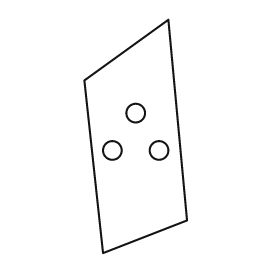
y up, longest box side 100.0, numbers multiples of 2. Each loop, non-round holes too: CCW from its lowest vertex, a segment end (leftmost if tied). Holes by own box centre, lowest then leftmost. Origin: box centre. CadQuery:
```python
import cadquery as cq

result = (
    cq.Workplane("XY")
    .moveTo(-14.0, -50.0)
    .lineTo(22.0, -36.0)
    .lineTo(14.0, 50.0)
    .lineTo(-22.0, 24.0)
    .close()
    .moveTo(-10.0, -6.0)
    .circle(4.0)
    .moveTo(10.0, -6.0)
    .circle(4.0)
    .moveTo(0.0, 10.0)
    .circle(4.0)
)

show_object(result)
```